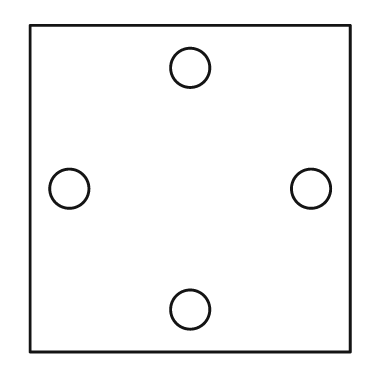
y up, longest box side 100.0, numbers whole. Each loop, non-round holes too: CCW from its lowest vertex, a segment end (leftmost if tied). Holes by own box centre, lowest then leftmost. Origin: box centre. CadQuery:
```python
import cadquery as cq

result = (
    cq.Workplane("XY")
    .moveTo(-49.0, -50.0)
    .lineTo(49.0, -50.0)
    .lineTo(49.0, 50.0)
    .lineTo(-49.0, 50.0)
    .close()
    .moveTo(0.0, -37.0)
    .circle(6.0)
    .moveTo(-37.0, 0.0)
    .circle(6.0)
    .moveTo(37.0, 0.0)
    .circle(6.0)
    .moveTo(0.0, 37.0)
    .circle(6.0)
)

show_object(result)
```